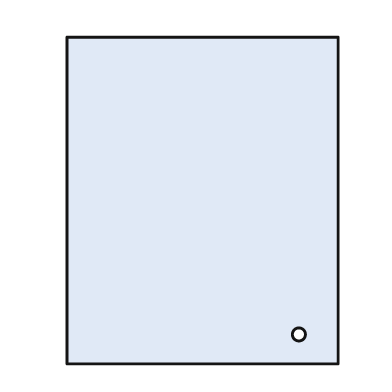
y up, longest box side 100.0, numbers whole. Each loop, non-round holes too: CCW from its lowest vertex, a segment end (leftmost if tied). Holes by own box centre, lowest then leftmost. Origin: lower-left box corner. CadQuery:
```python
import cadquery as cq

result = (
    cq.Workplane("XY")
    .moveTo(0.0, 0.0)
    .lineTo(83.0, 0.0)
    .lineTo(83.0, 100.0)
    .lineTo(0.0, 100.0)
    .close()
    .moveTo(71.0, 9.0)
    .circle(2.0)
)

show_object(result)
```